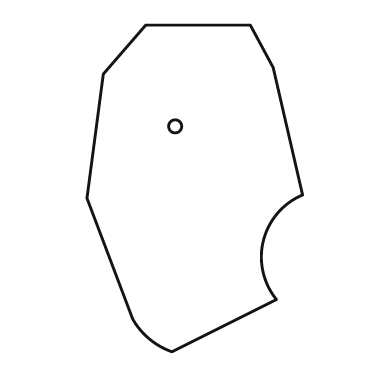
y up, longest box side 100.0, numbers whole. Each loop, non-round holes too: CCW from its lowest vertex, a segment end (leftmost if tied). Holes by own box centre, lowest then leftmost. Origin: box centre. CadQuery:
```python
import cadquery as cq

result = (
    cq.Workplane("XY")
    .moveTo(-7.0, -50.0)
    .lineTo(25.0, -34.0)
    .threePointArc((21.0, -16.0), (33.0, -2.0))
    .lineTo(24.0, 37.0)
    .lineTo(17.0, 50.0)
    .lineTo(-15.0, 50.0)
    .lineTo(-28.0, 35.0)
    .lineTo(-33.0, -3.0)
    .lineTo(-19.0, -40.0)
    .threePointArc((-14.0, -46.0), (-7.0, -50.0))
    .close()
    .moveTo(-6.0, 19.0)
    .circle(2.0)
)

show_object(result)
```